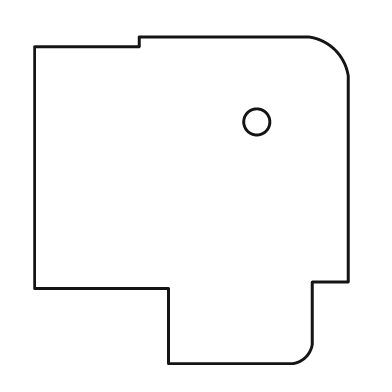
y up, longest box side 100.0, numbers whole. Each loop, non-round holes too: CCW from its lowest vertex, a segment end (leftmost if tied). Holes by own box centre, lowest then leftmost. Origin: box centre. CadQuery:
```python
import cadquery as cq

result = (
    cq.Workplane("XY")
    .moveTo(-7.0, -50.0)
    .lineTo(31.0, -50.0)
    .threePointArc((35.0, -48.0), (37.0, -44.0))
    .lineTo(37.0, -25.0)
    .lineTo(48.0, -25.0)
    .lineTo(48.0, 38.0)
    .threePointArc((44.0, 46.0), (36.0, 50.0))
    .lineTo(-16.0, 50.0)
    .lineTo(-16.0, 47.0)
    .lineTo(-48.0, 47.0)
    .lineTo(-48.0, -27.0)
    .lineTo(-7.0, -27.0)
    .close()
    .moveTo(20.0, 24.0)
    .circle(4.0)
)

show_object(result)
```